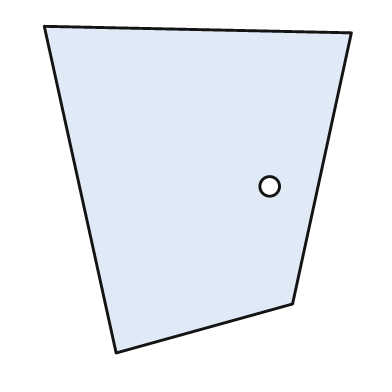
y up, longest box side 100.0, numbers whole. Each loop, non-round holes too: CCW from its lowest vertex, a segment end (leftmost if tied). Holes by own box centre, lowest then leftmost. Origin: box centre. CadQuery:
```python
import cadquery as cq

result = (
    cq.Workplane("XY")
    .moveTo(-25.0, -50.0)
    .lineTo(29.0, -35.0)
    .lineTo(47.0, 48.0)
    .lineTo(-47.0, 50.0)
    .close()
    .moveTo(22.0, 1.0)
    .circle(3.0)
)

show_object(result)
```